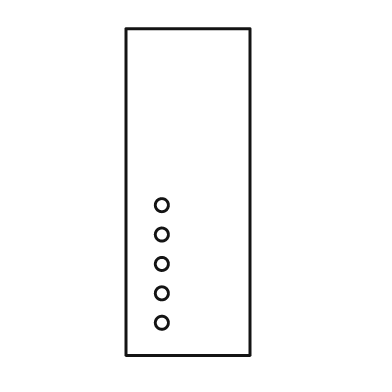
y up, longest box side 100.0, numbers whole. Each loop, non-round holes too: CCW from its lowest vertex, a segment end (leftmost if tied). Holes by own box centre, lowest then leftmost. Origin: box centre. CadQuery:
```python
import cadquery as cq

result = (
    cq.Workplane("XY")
    .moveTo(-19.0, -50.0)
    .lineTo(19.0, -50.0)
    .lineTo(19.0, 50.0)
    .lineTo(-19.0, 50.0)
    .close()
    .moveTo(-8.0, -40.0)
    .circle(2.0)
    .moveTo(-8.0, -31.0)
    .circle(2.0)
    .moveTo(-8.0, -22.0)
    .circle(2.0)
    .moveTo(-8.0, -13.0)
    .circle(2.0)
    .moveTo(-8.0, -4.0)
    .circle(2.0)
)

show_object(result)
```